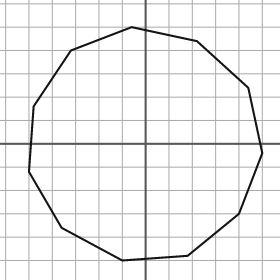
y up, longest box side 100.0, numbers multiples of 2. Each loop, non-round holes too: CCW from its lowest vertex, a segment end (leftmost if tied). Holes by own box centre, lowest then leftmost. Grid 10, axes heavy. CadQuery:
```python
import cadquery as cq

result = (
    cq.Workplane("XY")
    .moveTo(-10.0, -50.0)
    .lineTo(18.0, -48.0)
    .lineTo(40.0, -30.0)
    .lineTo(50.0, -4.0)
    .lineTo(44.0, 24.0)
    .lineTo(22.0, 44.0)
    .lineTo(-6.0, 50.0)
    .lineTo(-32.0, 40.0)
    .lineTo(-48.0, 16.0)
    .lineTo(-50.0, -12.0)
    .lineTo(-36.0, -36.0)
    .close()
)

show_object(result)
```